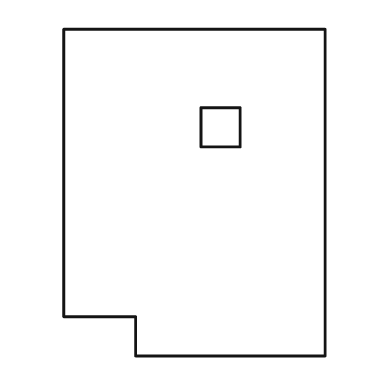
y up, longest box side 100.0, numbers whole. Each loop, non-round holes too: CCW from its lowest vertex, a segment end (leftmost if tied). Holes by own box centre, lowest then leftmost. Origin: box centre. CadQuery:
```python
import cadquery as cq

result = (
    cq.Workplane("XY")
    .moveTo(-18.0, -50.0)
    .lineTo(40.0, -50.0)
    .lineTo(40.0, 50.0)
    .lineTo(-40.0, 50.0)
    .lineTo(-40.0, -38.0)
    .lineTo(-18.0, -38.0)
    .close()
    .moveTo(2.0, 14.0)
    .lineTo(14.0, 14.0)
    .lineTo(14.0, 26.0)
    .lineTo(2.0, 26.0)
    .close()
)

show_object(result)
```